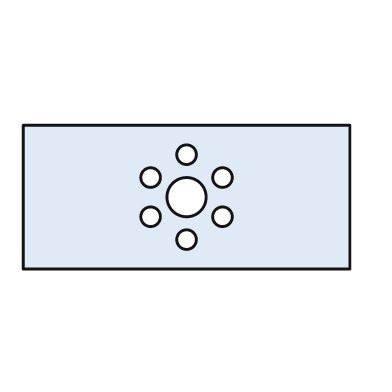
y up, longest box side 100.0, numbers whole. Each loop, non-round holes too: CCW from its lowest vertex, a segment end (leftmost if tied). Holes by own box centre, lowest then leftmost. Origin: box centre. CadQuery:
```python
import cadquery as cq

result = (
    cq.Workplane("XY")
    .moveTo(-50.0, -22.0)
    .lineTo(50.0, -22.0)
    .lineTo(50.0, 22.0)
    .lineTo(-50.0, 22.0)
    .close()
    .moveTo(0.0, -13.0)
    .circle(3.0)
    .moveTo(-11.0, -6.0)
    .circle(3.0)
    .moveTo(11.0, -6.0)
    .circle(3.0)
    .moveTo(0.0, 0.0)
    .circle(6.0)
    .moveTo(-11.0, 6.0)
    .circle(3.0)
    .moveTo(11.0, 6.0)
    .circle(3.0)
    .moveTo(0.0, 13.0)
    .circle(3.0)
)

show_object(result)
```